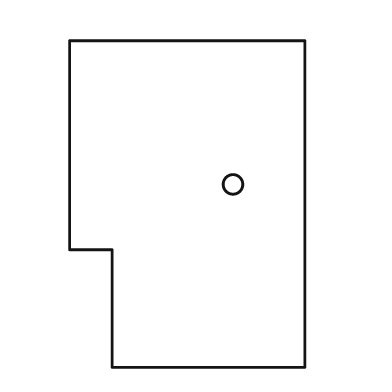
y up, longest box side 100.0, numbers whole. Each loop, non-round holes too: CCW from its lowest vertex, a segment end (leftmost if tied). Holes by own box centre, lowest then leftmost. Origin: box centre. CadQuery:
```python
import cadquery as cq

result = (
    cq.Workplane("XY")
    .moveTo(-23.0, -50.0)
    .lineTo(36.0, -50.0)
    .lineTo(36.0, 50.0)
    .lineTo(-36.0, 50.0)
    .lineTo(-36.0, -14.0)
    .lineTo(-23.0, -14.0)
    .close()
    .moveTo(14.0, 6.0)
    .circle(3.0)
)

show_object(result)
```